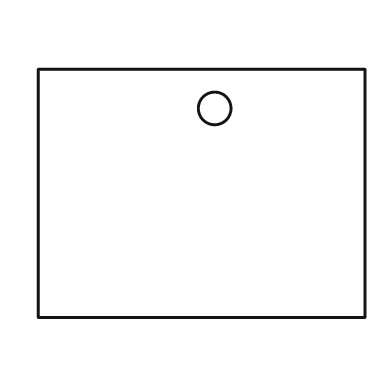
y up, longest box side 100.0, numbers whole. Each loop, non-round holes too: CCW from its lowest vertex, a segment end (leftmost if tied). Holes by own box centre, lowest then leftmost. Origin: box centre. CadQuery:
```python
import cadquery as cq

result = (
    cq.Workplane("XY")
    .moveTo(-50.0, -38.0)
    .lineTo(50.0, -38.0)
    .lineTo(50.0, 38.0)
    .lineTo(-50.0, 38.0)
    .close()
    .moveTo(4.0, 26.0)
    .circle(5.0)
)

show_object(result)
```